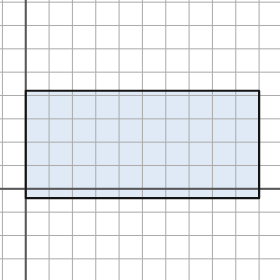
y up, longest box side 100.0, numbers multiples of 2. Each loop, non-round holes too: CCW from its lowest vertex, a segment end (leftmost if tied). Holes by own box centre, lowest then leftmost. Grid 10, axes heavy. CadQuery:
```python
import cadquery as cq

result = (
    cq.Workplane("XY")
    .moveTo(0.0, -4.0)
    .lineTo(100.0, -4.0)
    .lineTo(100.0, 42.0)
    .lineTo(0.0, 42.0)
    .close()
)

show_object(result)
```